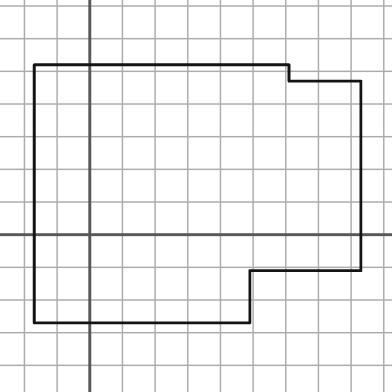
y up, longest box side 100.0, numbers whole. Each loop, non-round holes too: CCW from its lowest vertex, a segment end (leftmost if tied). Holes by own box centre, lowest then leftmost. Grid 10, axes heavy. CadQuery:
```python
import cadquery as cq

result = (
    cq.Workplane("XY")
    .moveTo(-17.0, -27.0)
    .lineTo(49.0, -27.0)
    .lineTo(49.0, -11.0)
    .lineTo(83.0, -11.0)
    .lineTo(83.0, 47.0)
    .lineTo(61.0, 47.0)
    .lineTo(61.0, 52.0)
    .lineTo(-17.0, 52.0)
    .close()
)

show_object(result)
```